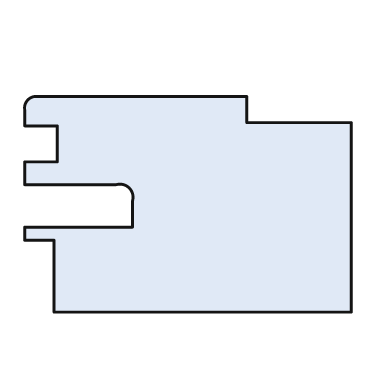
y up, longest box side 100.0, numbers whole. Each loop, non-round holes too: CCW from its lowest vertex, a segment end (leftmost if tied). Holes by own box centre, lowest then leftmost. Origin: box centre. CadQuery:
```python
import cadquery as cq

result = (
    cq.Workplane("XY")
    .moveTo(-41.0, -33.0)
    .lineTo(50.0, -33.0)
    .lineTo(50.0, 25.0)
    .lineTo(18.0, 25.0)
    .lineTo(18.0, 33.0)
    .lineTo(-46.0, 33.0)
    .threePointArc((-49.0, 32.0), (-50.0, 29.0))
    .lineTo(-50.0, 24.0)
    .lineTo(-40.0, 24.0)
    .lineTo(-40.0, 13.0)
    .lineTo(-50.0, 13.0)
    .lineTo(-50.0, 6.0)
    .lineTo(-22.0, 6.0)
    .threePointArc((-18.0, 5.0), (-17.0, 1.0))
    .lineTo(-17.0, -7.0)
    .lineTo(-50.0, -7.0)
    .lineTo(-50.0, -11.0)
    .lineTo(-41.0, -11.0)
    .close()
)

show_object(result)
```